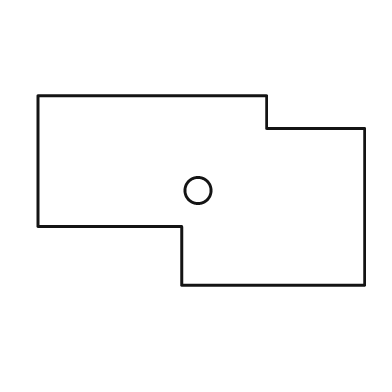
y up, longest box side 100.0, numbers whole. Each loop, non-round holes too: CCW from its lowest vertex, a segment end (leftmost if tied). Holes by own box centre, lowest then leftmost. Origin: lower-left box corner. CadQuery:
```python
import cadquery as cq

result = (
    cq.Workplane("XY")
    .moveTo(44.0, 0.0)
    .lineTo(100.0, 0.0)
    .lineTo(100.0, 48.0)
    .lineTo(70.0, 48.0)
    .lineTo(70.0, 58.0)
    .lineTo(0.0, 58.0)
    .lineTo(0.0, 18.0)
    .lineTo(44.0, 18.0)
    .close()
    .moveTo(49.0, 29.0)
    .circle(4.0)
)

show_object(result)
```